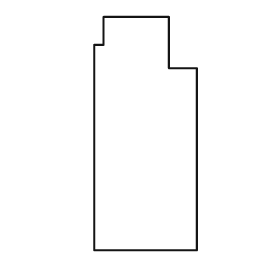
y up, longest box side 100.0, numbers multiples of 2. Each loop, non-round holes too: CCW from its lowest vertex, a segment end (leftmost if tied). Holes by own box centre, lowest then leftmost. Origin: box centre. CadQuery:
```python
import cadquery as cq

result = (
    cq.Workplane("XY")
    .moveTo(-22.0, -50.0)
    .lineTo(22.0, -50.0)
    .lineTo(22.0, 28.0)
    .lineTo(10.0, 28.0)
    .lineTo(10.0, 50.0)
    .lineTo(-18.0, 50.0)
    .lineTo(-18.0, 38.0)
    .lineTo(-22.0, 38.0)
    .close()
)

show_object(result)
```